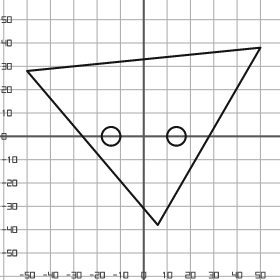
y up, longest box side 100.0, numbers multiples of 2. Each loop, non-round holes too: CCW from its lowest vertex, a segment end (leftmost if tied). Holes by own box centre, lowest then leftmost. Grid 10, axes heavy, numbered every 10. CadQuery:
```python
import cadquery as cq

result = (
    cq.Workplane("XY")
    .moveTo(6.0, -38.0)
    .lineTo(50.0, 38.0)
    .lineTo(-50.0, 28.0)
    .close()
    .moveTo(-14.0, 0.0)
    .circle(4.0)
    .moveTo(14.0, 0.0)
    .circle(4.0)
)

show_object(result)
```